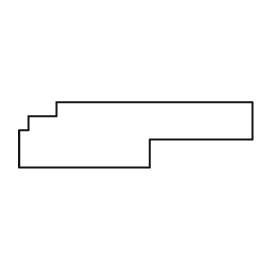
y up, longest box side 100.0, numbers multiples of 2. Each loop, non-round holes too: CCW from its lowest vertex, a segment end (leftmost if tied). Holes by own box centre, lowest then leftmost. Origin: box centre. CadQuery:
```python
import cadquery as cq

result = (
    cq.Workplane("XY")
    .moveTo(-50.0, -14.0)
    .lineTo(6.0, -14.0)
    .lineTo(6.0, -2.0)
    .lineTo(50.0, -2.0)
    .lineTo(50.0, 14.0)
    .lineTo(-34.0, 14.0)
    .lineTo(-34.0, 8.0)
    .lineTo(-46.0, 8.0)
    .lineTo(-46.0, 2.0)
    .lineTo(-50.0, 2.0)
    .close()
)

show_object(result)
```